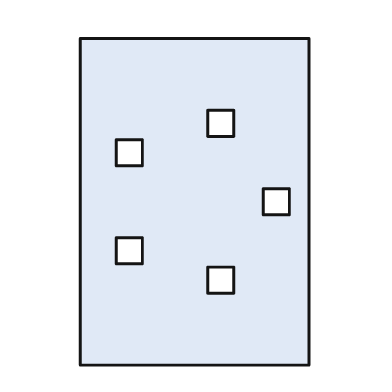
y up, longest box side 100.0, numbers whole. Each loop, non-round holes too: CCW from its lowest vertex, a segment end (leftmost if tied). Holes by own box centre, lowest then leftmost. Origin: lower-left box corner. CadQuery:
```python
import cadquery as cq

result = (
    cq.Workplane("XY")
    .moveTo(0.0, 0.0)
    .lineTo(70.0, 0.0)
    .lineTo(70.0, 100.0)
    .lineTo(0.0, 100.0)
    .close()
    .moveTo(39.0, 22.0)
    .lineTo(47.0, 22.0)
    .lineTo(47.0, 30.0)
    .lineTo(39.0, 30.0)
    .close()
    .moveTo(11.0, 31.0)
    .lineTo(19.0, 31.0)
    .lineTo(19.0, 39.0)
    .lineTo(11.0, 39.0)
    .close()
    .moveTo(56.0, 46.0)
    .lineTo(64.0, 46.0)
    .lineTo(64.0, 54.0)
    .lineTo(56.0, 54.0)
    .close()
    .moveTo(11.0, 61.0)
    .lineTo(19.0, 61.0)
    .lineTo(19.0, 69.0)
    .lineTo(11.0, 69.0)
    .close()
    .moveTo(39.0, 70.0)
    .lineTo(47.0, 70.0)
    .lineTo(47.0, 78.0)
    .lineTo(39.0, 78.0)
    .close()
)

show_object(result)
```